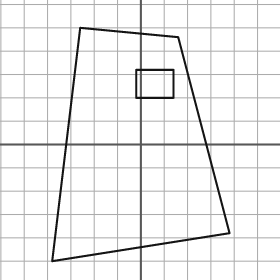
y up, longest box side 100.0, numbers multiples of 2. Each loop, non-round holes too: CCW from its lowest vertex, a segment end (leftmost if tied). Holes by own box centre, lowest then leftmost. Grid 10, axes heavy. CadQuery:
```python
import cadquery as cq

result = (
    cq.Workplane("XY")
    .moveTo(-38.0, -50.0)
    .lineTo(38.0, -38.0)
    .lineTo(16.0, 46.0)
    .lineTo(-26.0, 50.0)
    .close()
    .moveTo(-2.0, 20.0)
    .lineTo(14.0, 20.0)
    .lineTo(14.0, 32.0)
    .lineTo(-2.0, 32.0)
    .close()
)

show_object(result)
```